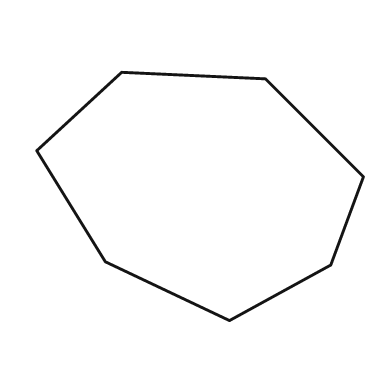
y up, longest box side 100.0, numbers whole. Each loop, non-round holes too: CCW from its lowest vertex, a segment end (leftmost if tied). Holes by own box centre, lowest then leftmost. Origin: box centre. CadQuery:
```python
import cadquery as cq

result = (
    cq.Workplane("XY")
    .moveTo(9.0, -38.0)
    .lineTo(40.0, -21.0)
    .lineTo(50.0, 6.0)
    .lineTo(20.0, 36.0)
    .lineTo(-24.0, 38.0)
    .lineTo(-50.0, 14.0)
    .lineTo(-29.0, -20.0)
    .close()
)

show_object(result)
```